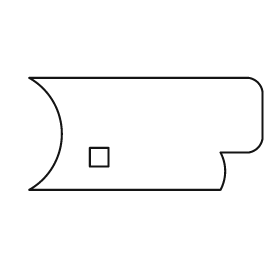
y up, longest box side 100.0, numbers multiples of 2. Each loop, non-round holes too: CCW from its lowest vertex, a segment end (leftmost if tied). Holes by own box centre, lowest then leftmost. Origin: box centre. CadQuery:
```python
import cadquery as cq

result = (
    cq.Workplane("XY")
    .moveTo(-50.0, -24.0)
    .lineTo(32.0, -24.0)
    .threePointArc((34.0, -16.0), (32.0, -8.0))
    .lineTo(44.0, -8.0)
    .threePointArc((48.0, -6.0), (50.0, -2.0))
    .lineTo(50.0, 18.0)
    .threePointArc((48.0, 22.0), (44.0, 24.0))
    .lineTo(-50.0, 24.0)
    .threePointArc((-36.0, 0.0), (-50.0, -24.0))
    .close()
    .moveTo(-24.0, -14.0)
    .lineTo(-16.0, -14.0)
    .lineTo(-16.0, -6.0)
    .lineTo(-24.0, -6.0)
    .close()
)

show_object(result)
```